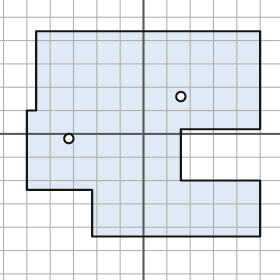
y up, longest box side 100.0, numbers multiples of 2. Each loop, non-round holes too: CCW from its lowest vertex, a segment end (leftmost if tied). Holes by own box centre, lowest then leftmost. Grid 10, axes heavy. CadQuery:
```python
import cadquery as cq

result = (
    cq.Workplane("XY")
    .moveTo(-22.0, -44.0)
    .lineTo(50.0, -44.0)
    .lineTo(50.0, -20.0)
    .lineTo(16.0, -20.0)
    .lineTo(16.0, 2.0)
    .lineTo(50.0, 2.0)
    .lineTo(50.0, 44.0)
    .lineTo(-46.0, 44.0)
    .lineTo(-46.0, 10.0)
    .lineTo(-50.0, 10.0)
    .lineTo(-50.0, -24.0)
    .lineTo(-22.0, -24.0)
    .close()
    .moveTo(-32.0, -2.0)
    .circle(2.0)
    .moveTo(16.0, 16.0)
    .circle(2.0)
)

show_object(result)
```